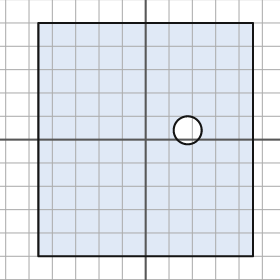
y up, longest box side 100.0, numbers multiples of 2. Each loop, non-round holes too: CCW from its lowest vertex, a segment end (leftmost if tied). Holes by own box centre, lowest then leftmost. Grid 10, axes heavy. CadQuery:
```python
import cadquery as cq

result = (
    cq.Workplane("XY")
    .moveTo(-46.0, -50.0)
    .lineTo(46.0, -50.0)
    .lineTo(46.0, 50.0)
    .lineTo(-46.0, 50.0)
    .close()
    .moveTo(18.0, 4.0)
    .circle(6.0)
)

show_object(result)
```